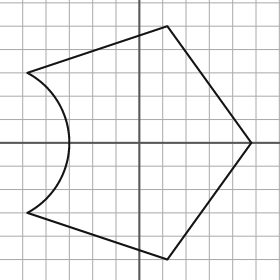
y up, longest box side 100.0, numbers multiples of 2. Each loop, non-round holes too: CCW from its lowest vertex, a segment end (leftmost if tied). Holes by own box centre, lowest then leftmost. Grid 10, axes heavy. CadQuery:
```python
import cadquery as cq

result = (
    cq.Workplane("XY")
    .moveTo(12.0, -50.0)
    .lineTo(48.0, 0.0)
    .lineTo(12.0, 50.0)
    .lineTo(-48.0, 30.0)
    .threePointArc((-30.0, 0.0), (-48.0, -30.0))
    .close()
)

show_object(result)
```